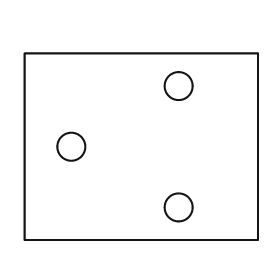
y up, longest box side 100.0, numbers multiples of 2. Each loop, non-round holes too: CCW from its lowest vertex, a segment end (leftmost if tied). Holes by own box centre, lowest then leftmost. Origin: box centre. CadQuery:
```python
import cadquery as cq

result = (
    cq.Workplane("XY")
    .moveTo(-50.0, -40.0)
    .lineTo(50.0, -40.0)
    .lineTo(50.0, 40.0)
    .lineTo(-50.0, 40.0)
    .close()
    .moveTo(16.0, -26.0)
    .circle(6.0)
    .moveTo(-30.0, 0.0)
    .circle(6.0)
    .moveTo(16.0, 26.0)
    .circle(6.0)
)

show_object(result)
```